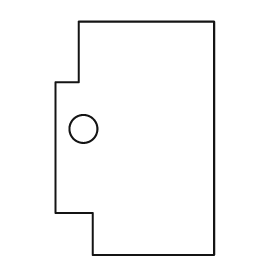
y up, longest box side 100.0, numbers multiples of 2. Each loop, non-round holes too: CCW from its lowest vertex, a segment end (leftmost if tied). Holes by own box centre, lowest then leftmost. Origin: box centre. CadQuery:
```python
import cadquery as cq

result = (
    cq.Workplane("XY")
    .moveTo(-18.0, -50.0)
    .lineTo(34.0, -50.0)
    .lineTo(34.0, 50.0)
    .lineTo(-24.0, 50.0)
    .lineTo(-24.0, 24.0)
    .lineTo(-34.0, 24.0)
    .lineTo(-34.0, -32.0)
    .lineTo(-18.0, -32.0)
    .close()
    .moveTo(-22.0, 4.0)
    .circle(6.0)
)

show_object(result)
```